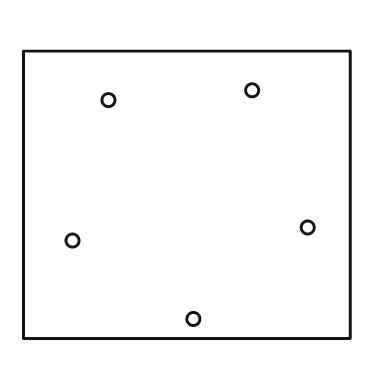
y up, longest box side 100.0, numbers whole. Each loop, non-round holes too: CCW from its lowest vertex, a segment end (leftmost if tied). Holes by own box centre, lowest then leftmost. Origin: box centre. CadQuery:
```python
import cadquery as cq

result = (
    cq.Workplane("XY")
    .moveTo(-50.0, -44.0)
    .lineTo(50.0, -44.0)
    .lineTo(50.0, 44.0)
    .lineTo(-50.0, 44.0)
    .close()
    .moveTo(2.0, -38.0)
    .circle(2.0)
    .moveTo(-35.0, -14.0)
    .circle(2.0)
    .moveTo(37.0, -10.0)
    .circle(2.0)
    .moveTo(-24.0, 29.0)
    .circle(2.0)
    .moveTo(20.0, 32.0)
    .circle(2.0)
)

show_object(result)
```